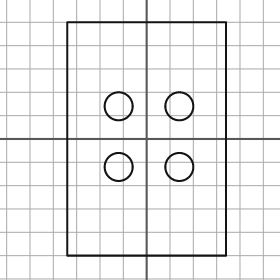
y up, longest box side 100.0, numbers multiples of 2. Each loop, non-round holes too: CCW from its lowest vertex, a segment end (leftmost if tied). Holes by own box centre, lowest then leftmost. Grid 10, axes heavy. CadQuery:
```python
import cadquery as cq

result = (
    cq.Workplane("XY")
    .moveTo(-34.0, -50.0)
    .lineTo(34.0, -50.0)
    .lineTo(34.0, 50.0)
    .lineTo(-34.0, 50.0)
    .close()
    .moveTo(-12.0, -12.0)
    .circle(6.0)
    .moveTo(14.0, -12.0)
    .circle(6.0)
    .moveTo(-12.0, 14.0)
    .circle(6.0)
    .moveTo(14.0, 14.0)
    .circle(6.0)
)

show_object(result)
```